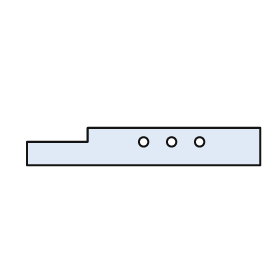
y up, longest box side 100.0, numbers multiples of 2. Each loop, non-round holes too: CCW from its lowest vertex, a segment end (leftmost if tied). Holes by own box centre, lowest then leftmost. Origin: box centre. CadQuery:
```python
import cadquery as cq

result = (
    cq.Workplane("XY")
    .moveTo(-50.0, -8.0)
    .lineTo(50.0, -8.0)
    .lineTo(50.0, 8.0)
    .lineTo(-24.0, 8.0)
    .lineTo(-24.0, 2.0)
    .lineTo(-50.0, 2.0)
    .close()
    .moveTo(0.0, 2.0)
    .circle(2.0)
    .moveTo(12.0, 2.0)
    .circle(2.0)
    .moveTo(24.0, 2.0)
    .circle(2.0)
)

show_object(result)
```